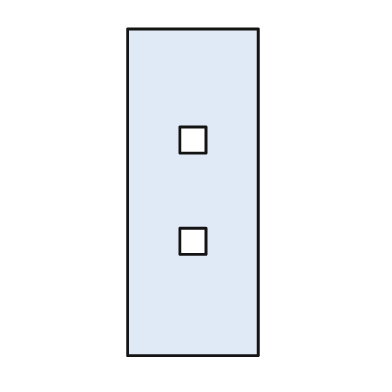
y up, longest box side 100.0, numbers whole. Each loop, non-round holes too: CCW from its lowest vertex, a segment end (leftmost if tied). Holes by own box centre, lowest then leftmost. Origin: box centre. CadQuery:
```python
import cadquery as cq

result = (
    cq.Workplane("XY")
    .moveTo(-20.0, -50.0)
    .lineTo(20.0, -50.0)
    .lineTo(20.0, 50.0)
    .lineTo(-20.0, 50.0)
    .close()
    .moveTo(-4.0, -19.0)
    .lineTo(4.0, -19.0)
    .lineTo(4.0, -11.0)
    .lineTo(-4.0, -11.0)
    .close()
    .moveTo(-4.0, 12.0)
    .lineTo(4.0, 12.0)
    .lineTo(4.0, 20.0)
    .lineTo(-4.0, 20.0)
    .close()
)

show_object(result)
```